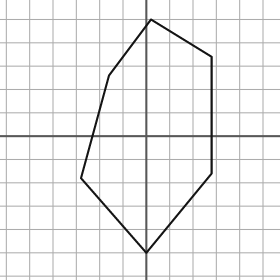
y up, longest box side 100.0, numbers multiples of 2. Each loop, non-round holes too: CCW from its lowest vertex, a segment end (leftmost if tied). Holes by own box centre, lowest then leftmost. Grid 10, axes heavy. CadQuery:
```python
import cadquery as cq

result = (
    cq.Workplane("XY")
    .moveTo(0.0, -50.0)
    .lineTo(28.0, -16.0)
    .lineTo(28.0, 34.0)
    .lineTo(2.0, 50.0)
    .lineTo(-16.0, 26.0)
    .lineTo(-28.0, -18.0)
    .close()
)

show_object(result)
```